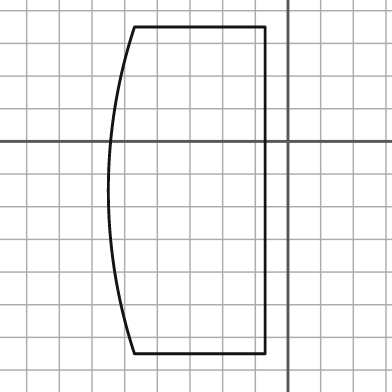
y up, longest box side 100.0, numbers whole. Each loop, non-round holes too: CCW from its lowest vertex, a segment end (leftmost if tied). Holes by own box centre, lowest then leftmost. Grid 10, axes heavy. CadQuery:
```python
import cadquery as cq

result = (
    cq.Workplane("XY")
    .moveTo(-47.0, -65.0)
    .lineTo(-7.0, -65.0)
    .lineTo(-7.0, 35.0)
    .lineTo(-47.0, 35.0)
    .threePointArc((-55.0, -15.0), (-47.0, -65.0))
    .close()
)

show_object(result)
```